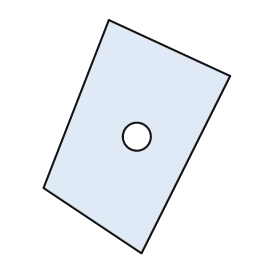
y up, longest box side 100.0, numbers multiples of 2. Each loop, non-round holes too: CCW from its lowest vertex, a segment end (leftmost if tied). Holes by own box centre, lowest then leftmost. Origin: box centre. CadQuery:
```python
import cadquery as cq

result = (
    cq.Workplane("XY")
    .moveTo(2.0, -50.0)
    .lineTo(40.0, 26.0)
    .lineTo(-12.0, 50.0)
    .lineTo(-40.0, -22.0)
    .close()
    .moveTo(0.0, 0.0)
    .circle(6.0)
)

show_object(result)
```